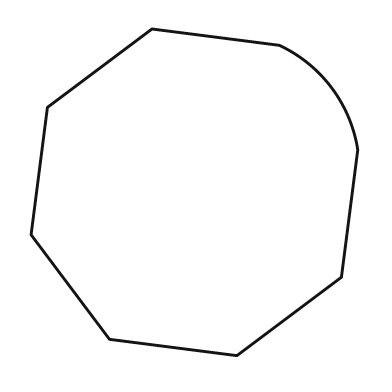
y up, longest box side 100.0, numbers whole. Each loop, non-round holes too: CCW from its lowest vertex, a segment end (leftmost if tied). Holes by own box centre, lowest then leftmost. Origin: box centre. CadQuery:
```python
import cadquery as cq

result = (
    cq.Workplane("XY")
    .moveTo(13.0, -50.0)
    .lineTo(45.0, -26.0)
    .lineTo(50.0, 13.0)
    .threePointArc((42.0, 32.0), (26.0, 45.0))
    .lineTo(-13.0, 50.0)
    .lineTo(-45.0, 26.0)
    .lineTo(-50.0, -13.0)
    .lineTo(-26.0, -45.0)
    .close()
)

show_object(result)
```